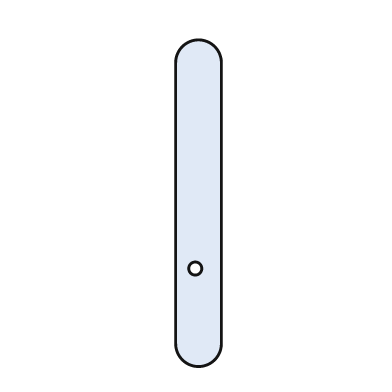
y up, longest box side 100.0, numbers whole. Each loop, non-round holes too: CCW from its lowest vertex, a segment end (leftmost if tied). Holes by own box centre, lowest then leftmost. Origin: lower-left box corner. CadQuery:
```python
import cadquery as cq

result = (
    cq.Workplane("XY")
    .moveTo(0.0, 7.0)
    .threePointArc((7.0, 0.0), (14.0, 7.0))
    .lineTo(14.0, 93.0)
    .threePointArc((7.0, 100.0), (0.0, 93.0))
    .close()
    .moveTo(6.0, 30.0)
    .circle(2.0)
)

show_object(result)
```